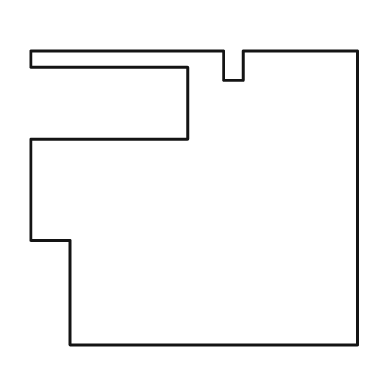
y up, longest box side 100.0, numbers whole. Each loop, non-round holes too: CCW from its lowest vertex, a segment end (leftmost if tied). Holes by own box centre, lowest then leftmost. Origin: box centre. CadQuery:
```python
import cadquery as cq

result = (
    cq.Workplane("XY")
    .moveTo(-38.0, -45.0)
    .lineTo(50.0, -45.0)
    .lineTo(50.0, 45.0)
    .lineTo(15.0, 45.0)
    .lineTo(15.0, 36.0)
    .lineTo(9.0, 36.0)
    .lineTo(9.0, 45.0)
    .lineTo(-50.0, 45.0)
    .lineTo(-50.0, 40.0)
    .lineTo(-2.0, 40.0)
    .lineTo(-2.0, 18.0)
    .lineTo(-50.0, 18.0)
    .lineTo(-50.0, -13.0)
    .lineTo(-38.0, -13.0)
    .close()
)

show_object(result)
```